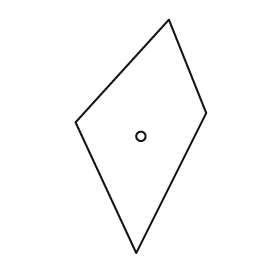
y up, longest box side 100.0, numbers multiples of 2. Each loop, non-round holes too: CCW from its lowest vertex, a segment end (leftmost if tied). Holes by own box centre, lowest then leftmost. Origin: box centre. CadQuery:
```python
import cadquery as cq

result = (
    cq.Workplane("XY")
    .moveTo(-2.0, -50.0)
    .lineTo(28.0, 10.0)
    .lineTo(12.0, 50.0)
    .lineTo(-28.0, 6.0)
    .close()
    .moveTo(0.0, 0.0)
    .circle(2.0)
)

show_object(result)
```